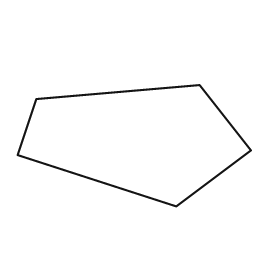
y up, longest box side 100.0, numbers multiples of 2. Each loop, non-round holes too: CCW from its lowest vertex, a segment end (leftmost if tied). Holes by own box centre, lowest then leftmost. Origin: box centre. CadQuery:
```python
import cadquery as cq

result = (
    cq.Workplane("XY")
    .moveTo(18.0, -26.0)
    .lineTo(50.0, -2.0)
    .lineTo(28.0, 26.0)
    .lineTo(-42.0, 20.0)
    .lineTo(-50.0, -4.0)
    .close()
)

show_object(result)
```